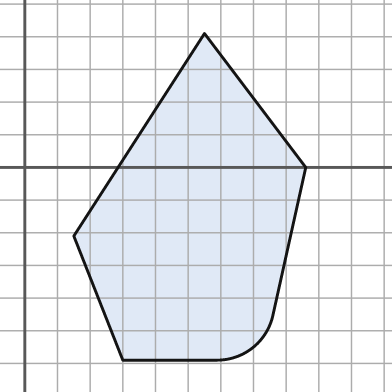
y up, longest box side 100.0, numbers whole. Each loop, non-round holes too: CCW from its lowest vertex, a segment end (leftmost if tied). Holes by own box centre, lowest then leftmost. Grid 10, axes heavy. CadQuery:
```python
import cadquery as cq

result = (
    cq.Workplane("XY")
    .moveTo(30.0, -59.0)
    .lineTo(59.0, -59.0)
    .threePointArc((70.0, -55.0), (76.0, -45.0))
    .lineTo(86.0, 0.0)
    .lineTo(55.0, 41.0)
    .lineTo(15.0, -21.0)
    .close()
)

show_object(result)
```